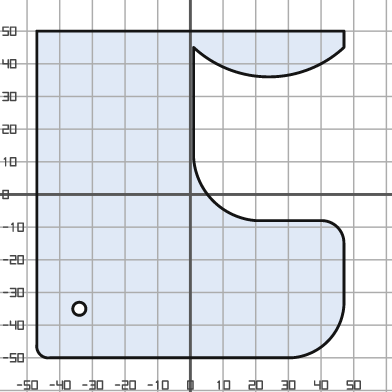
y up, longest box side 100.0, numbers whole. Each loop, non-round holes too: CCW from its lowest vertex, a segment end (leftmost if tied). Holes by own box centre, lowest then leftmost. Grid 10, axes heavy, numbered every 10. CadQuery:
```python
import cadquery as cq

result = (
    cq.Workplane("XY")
    .moveTo(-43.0, -50.0)
    .lineTo(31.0, -50.0)
    .threePointArc((42.0, -45.0), (47.0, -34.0))
    .lineTo(47.0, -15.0)
    .threePointArc((45.0, -10.0), (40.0, -8.0))
    .lineTo(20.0, -8.0)
    .threePointArc((7.0, -2.0), (1.0, 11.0))
    .lineTo(1.0, 45.0)
    .threePointArc((24.0, 36.0), (47.0, 45.0))
    .lineTo(47.0, 50.0)
    .lineTo(-47.0, 50.0)
    .lineTo(-47.0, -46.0)
    .threePointArc((-46.0, -49.0), (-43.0, -50.0))
    .close()
    .moveTo(-34.0, -35.0)
    .circle(2.0)
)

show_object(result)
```